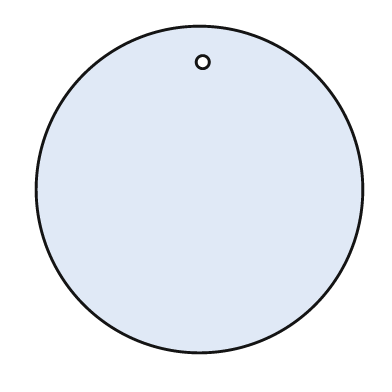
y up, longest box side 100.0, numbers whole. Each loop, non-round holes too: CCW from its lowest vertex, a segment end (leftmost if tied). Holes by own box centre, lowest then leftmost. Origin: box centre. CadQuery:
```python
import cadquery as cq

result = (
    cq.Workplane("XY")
    .moveTo(0.0, 0.0)
    .circle(50.0)
    .moveTo(1.0, 39.0)
    .circle(2.0)
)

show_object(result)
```